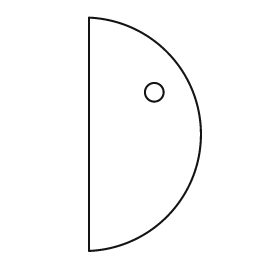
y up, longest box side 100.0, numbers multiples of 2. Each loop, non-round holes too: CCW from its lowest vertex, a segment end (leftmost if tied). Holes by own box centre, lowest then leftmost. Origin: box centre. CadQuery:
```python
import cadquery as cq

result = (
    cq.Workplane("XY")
    .moveTo(-24.0, -50.0)
    .threePointArc((24.0, 0.0), (-24.0, 50.0))
    .close()
    .moveTo(4.0, 18.0)
    .circle(4.0)
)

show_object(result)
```